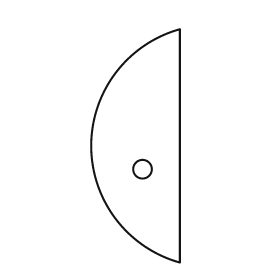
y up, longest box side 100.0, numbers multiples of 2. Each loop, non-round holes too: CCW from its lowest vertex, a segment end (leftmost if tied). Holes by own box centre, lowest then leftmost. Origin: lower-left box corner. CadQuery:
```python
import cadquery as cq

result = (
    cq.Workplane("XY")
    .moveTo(38.0, 0.0)
    .lineTo(38.0, 100.0)
    .threePointArc((0.0, 50.0), (38.0, 0.0))
    .close()
    .moveTo(22.0, 40.0)
    .circle(4.0)
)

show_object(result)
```